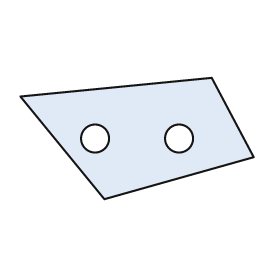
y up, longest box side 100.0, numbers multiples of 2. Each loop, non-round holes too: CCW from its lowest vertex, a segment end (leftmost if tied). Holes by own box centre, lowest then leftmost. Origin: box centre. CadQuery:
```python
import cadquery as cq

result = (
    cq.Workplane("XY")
    .moveTo(-14.0, -26.0)
    .lineTo(50.0, -8.0)
    .lineTo(32.0, 26.0)
    .lineTo(-50.0, 18.0)
    .close()
    .moveTo(-18.0, 0.0)
    .circle(6.0)
    .moveTo(18.0, 0.0)
    .circle(6.0)
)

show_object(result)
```